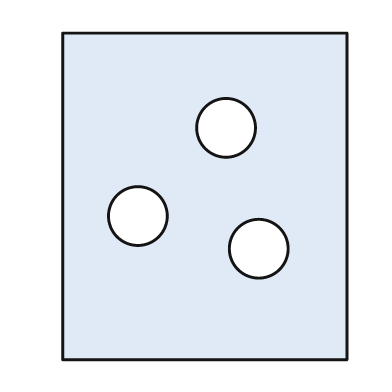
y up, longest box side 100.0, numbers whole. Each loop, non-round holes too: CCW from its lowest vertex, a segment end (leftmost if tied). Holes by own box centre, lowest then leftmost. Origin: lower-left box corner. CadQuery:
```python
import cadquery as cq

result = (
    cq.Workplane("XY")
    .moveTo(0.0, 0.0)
    .lineTo(87.0, 0.0)
    .lineTo(87.0, 100.0)
    .lineTo(0.0, 100.0)
    .close()
    .moveTo(60.0, 34.0)
    .circle(9.0)
    .moveTo(23.0, 44.0)
    .circle(9.0)
    .moveTo(50.0, 71.0)
    .circle(9.0)
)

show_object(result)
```